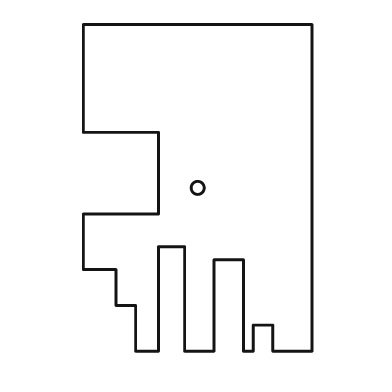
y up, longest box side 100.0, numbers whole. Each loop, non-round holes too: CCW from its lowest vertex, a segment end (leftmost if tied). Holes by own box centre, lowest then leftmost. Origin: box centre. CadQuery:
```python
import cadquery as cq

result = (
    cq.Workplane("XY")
    .moveTo(-19.0, -50.0)
    .lineTo(-12.0, -50.0)
    .lineTo(-12.0, -18.0)
    .lineTo(-4.0, -18.0)
    .lineTo(-4.0, -50.0)
    .lineTo(5.0, -50.0)
    .lineTo(5.0, -22.0)
    .lineTo(14.0, -22.0)
    .lineTo(14.0, -50.0)
    .lineTo(17.0, -50.0)
    .lineTo(17.0, -42.0)
    .lineTo(23.0, -42.0)
    .lineTo(23.0, -50.0)
    .lineTo(35.0, -50.0)
    .lineTo(35.0, 50.0)
    .lineTo(-35.0, 50.0)
    .lineTo(-35.0, 17.0)
    .lineTo(-12.0, 17.0)
    .lineTo(-12.0, -8.0)
    .lineTo(-35.0, -8.0)
    .lineTo(-35.0, -25.0)
    .lineTo(-25.0, -25.0)
    .lineTo(-25.0, -36.0)
    .lineTo(-19.0, -36.0)
    .close()
    .moveTo(0.0, 0.0)
    .circle(2.0)
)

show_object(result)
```